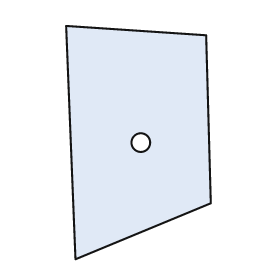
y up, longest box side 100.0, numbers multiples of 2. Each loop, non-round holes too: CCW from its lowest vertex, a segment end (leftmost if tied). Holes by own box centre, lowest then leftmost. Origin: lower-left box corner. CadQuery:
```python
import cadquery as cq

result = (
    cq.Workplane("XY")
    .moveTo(4.0, 0.0)
    .lineTo(62.0, 24.0)
    .lineTo(60.0, 96.0)
    .lineTo(0.0, 100.0)
    .close()
    .moveTo(32.0, 50.0)
    .circle(4.0)
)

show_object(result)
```